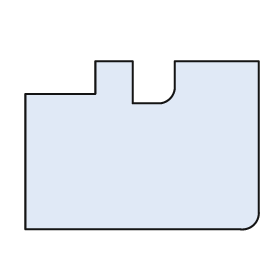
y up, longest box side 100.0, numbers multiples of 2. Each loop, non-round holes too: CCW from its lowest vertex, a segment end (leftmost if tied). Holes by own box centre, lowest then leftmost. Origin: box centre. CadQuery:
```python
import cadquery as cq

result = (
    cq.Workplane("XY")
    .moveTo(-50.0, -36.0)
    .lineTo(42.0, -36.0)
    .threePointArc((48.0, -34.0), (50.0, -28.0))
    .lineTo(50.0, 36.0)
    .lineTo(14.0, 36.0)
    .lineTo(14.0, 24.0)
    .threePointArc((12.0, 20.0), (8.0, 18.0))
    .lineTo(-4.0, 18.0)
    .lineTo(-4.0, 36.0)
    .lineTo(-20.0, 36.0)
    .lineTo(-20.0, 22.0)
    .lineTo(-50.0, 22.0)
    .close()
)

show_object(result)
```